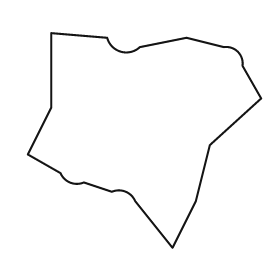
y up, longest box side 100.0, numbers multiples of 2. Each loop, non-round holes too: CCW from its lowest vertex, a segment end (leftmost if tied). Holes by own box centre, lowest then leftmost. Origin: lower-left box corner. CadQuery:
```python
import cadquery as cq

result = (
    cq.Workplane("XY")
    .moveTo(62.0, 0.0)
    .lineTo(72.0, 20.0)
    .lineTo(78.0, 44.0)
    .lineTo(100.0, 64.0)
    .lineTo(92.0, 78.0)
    .threePointArc((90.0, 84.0), (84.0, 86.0))
    .lineTo(68.0, 90.0)
    .lineTo(48.0, 86.0)
    .threePointArc((40.0, 84.0), (34.0, 90.0))
    .lineTo(10.0, 92.0)
    .lineTo(10.0, 60.0)
    .lineTo(0.0, 40.0)
    .lineTo(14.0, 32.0)
    .threePointArc((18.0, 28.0), (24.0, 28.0))
    .lineTo(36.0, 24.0)
    .threePointArc((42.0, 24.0), (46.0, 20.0))
    .close()
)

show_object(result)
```